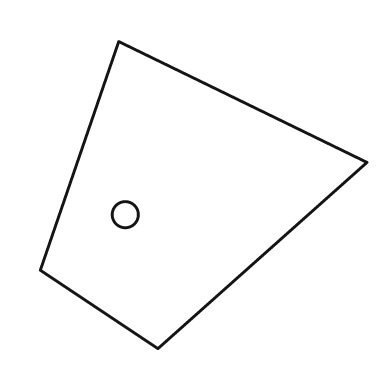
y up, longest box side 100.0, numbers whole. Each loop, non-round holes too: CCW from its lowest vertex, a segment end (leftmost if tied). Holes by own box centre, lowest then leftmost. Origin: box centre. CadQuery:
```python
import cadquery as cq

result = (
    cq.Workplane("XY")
    .moveTo(-14.0, -47.0)
    .lineTo(50.0, 10.0)
    .lineTo(-26.0, 47.0)
    .lineTo(-50.0, -23.0)
    .close()
    .moveTo(-24.0, -6.0)
    .circle(4.0)
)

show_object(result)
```